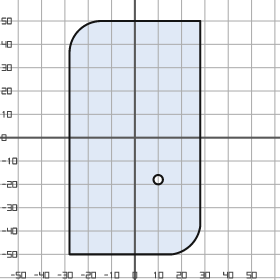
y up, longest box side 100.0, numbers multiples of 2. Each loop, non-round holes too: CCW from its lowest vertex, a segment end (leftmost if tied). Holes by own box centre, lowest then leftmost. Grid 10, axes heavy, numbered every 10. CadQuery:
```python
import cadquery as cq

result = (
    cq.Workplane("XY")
    .moveTo(-28.0, -50.0)
    .lineTo(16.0, -50.0)
    .threePointArc((24.0, -46.0), (28.0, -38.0))
    .lineTo(28.0, 50.0)
    .lineTo(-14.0, 50.0)
    .threePointArc((-24.0, 46.0), (-28.0, 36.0))
    .close()
    .moveTo(10.0, -18.0)
    .circle(2.0)
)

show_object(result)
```